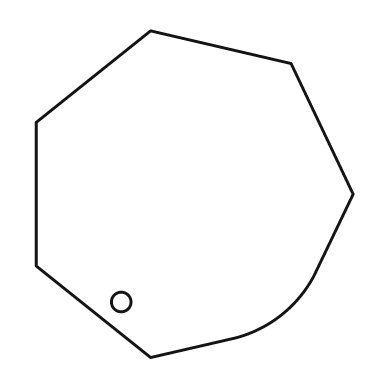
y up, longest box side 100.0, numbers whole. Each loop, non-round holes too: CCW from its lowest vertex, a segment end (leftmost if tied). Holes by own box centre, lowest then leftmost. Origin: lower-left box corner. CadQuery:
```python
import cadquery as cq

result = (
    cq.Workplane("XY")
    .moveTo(35.0, 0.0)
    .lineTo(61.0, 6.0)
    .threePointArc((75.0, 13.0), (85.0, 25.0))
    .lineTo(97.0, 50.0)
    .lineTo(78.0, 90.0)
    .lineTo(35.0, 100.0)
    .lineTo(0.0, 72.0)
    .lineTo(0.0, 28.0)
    .close()
    .moveTo(26.0, 17.0)
    .circle(3.0)
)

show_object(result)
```